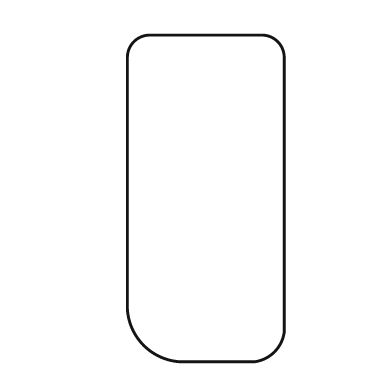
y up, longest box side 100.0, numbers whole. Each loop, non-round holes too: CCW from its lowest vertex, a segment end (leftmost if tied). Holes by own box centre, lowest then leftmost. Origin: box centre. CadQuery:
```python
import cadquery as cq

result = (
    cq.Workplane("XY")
    .moveTo(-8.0, -50.0)
    .lineTo(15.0, -50.0)
    .threePointArc((21.0, -47.0), (24.0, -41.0))
    .lineTo(24.0, 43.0)
    .threePointArc((22.0, 48.0), (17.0, 50.0))
    .lineTo(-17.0, 50.0)
    .threePointArc((-22.0, 48.0), (-24.0, 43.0))
    .lineTo(-24.0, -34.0)
    .threePointArc((-19.0, -45.0), (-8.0, -50.0))
    .close()
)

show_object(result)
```